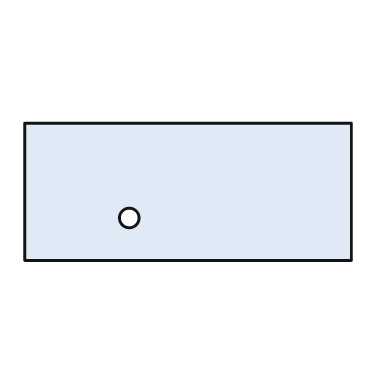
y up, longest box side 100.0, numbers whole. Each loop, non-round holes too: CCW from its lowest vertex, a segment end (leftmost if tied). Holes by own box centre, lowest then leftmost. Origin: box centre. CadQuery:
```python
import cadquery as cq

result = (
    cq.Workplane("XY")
    .moveTo(-50.0, -21.0)
    .lineTo(50.0, -21.0)
    .lineTo(50.0, 21.0)
    .lineTo(-50.0, 21.0)
    .close()
    .moveTo(-18.0, -8.0)
    .circle(3.0)
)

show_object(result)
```